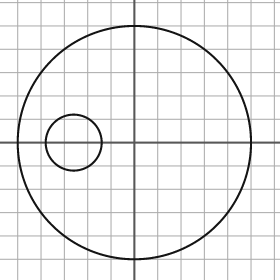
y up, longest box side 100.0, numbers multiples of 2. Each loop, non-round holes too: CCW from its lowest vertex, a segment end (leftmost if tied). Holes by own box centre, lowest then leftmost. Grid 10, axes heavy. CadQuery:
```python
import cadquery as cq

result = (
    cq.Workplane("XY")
    .moveTo(0.0, 0.0)
    .circle(50.0)
    .moveTo(-26.0, 0.0)
    .circle(12.0)
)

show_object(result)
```